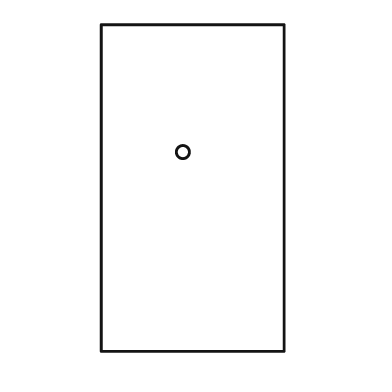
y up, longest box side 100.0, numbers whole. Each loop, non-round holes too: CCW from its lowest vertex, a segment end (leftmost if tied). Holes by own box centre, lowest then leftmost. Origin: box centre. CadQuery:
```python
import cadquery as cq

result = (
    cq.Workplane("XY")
    .moveTo(-28.0, -50.0)
    .lineTo(28.0, -50.0)
    .lineTo(28.0, 50.0)
    .lineTo(-28.0, 50.0)
    .close()
    .moveTo(-3.0, 11.0)
    .circle(2.0)
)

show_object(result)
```